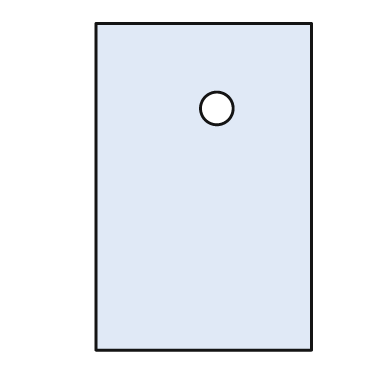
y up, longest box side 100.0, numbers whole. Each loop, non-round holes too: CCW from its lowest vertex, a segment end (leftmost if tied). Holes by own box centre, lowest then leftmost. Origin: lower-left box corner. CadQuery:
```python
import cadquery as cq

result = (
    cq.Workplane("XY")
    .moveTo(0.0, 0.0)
    .lineTo(66.0, 0.0)
    .lineTo(66.0, 100.0)
    .lineTo(0.0, 100.0)
    .close()
    .moveTo(37.0, 74.0)
    .circle(5.0)
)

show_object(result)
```